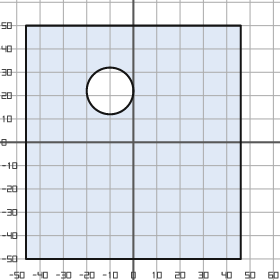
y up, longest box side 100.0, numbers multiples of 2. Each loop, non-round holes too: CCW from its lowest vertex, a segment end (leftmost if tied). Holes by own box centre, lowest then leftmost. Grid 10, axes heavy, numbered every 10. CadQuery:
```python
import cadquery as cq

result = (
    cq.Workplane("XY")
    .moveTo(-46.0, -50.0)
    .lineTo(46.0, -50.0)
    .lineTo(46.0, 50.0)
    .lineTo(-46.0, 50.0)
    .close()
    .moveTo(-10.0, 22.0)
    .circle(10.0)
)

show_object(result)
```